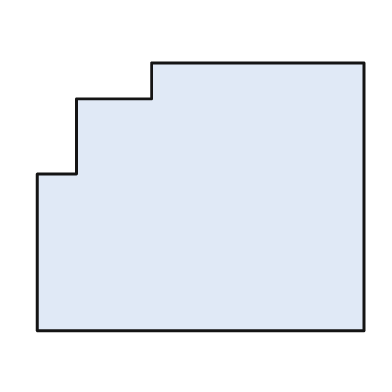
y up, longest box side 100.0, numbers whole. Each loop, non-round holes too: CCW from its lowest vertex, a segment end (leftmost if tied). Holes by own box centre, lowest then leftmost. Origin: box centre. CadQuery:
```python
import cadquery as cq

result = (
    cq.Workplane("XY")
    .moveTo(-50.0, -41.0)
    .lineTo(50.0, -41.0)
    .lineTo(50.0, 41.0)
    .lineTo(-15.0, 41.0)
    .lineTo(-15.0, 30.0)
    .lineTo(-38.0, 30.0)
    .lineTo(-38.0, 7.0)
    .lineTo(-50.0, 7.0)
    .close()
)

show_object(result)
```